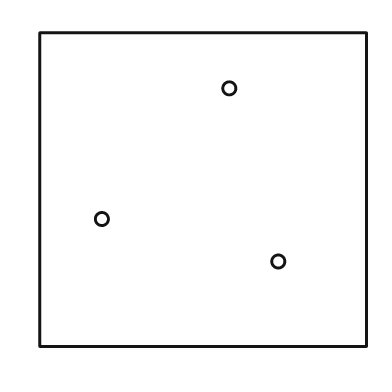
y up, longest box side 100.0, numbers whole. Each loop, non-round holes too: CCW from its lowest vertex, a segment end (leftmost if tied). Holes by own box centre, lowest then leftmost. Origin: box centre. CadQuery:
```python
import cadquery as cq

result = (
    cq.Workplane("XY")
    .moveTo(-50.0, -48.0)
    .lineTo(50.0, -48.0)
    .lineTo(50.0, 48.0)
    .lineTo(-50.0, 48.0)
    .close()
    .moveTo(23.0, -22.0)
    .circle(2.0)
    .moveTo(-31.0, -9.0)
    .circle(2.0)
    .moveTo(8.0, 31.0)
    .circle(2.0)
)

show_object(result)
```